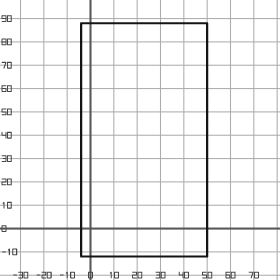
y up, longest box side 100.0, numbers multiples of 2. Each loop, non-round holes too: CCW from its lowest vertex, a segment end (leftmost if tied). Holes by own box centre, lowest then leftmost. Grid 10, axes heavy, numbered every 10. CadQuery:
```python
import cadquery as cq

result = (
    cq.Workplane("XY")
    .moveTo(-4.0, -12.0)
    .lineTo(50.0, -12.0)
    .lineTo(50.0, 88.0)
    .lineTo(-4.0, 88.0)
    .close()
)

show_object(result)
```